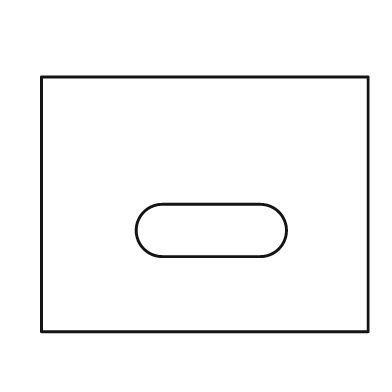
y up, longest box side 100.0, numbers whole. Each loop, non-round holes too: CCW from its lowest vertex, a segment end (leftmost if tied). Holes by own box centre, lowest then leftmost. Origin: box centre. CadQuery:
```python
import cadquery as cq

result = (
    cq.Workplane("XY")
    .moveTo(-50.0, -39.0)
    .lineTo(50.0, -39.0)
    .lineTo(50.0, 39.0)
    .lineTo(-50.0, 39.0)
    .close()
    .moveTo(-13.0, -16.0)
    .lineTo(17.0, -16.0)
    .threePointArc((25.0, -8.0), (17.0, 0.0))
    .lineTo(-13.0, 0.0)
    .threePointArc((-21.0, -8.0), (-13.0, -16.0))
    .close()
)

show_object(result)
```